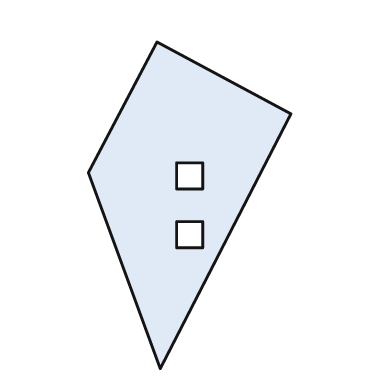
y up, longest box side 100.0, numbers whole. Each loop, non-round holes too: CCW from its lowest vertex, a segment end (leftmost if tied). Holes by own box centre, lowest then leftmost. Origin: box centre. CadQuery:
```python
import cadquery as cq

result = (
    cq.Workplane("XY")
    .moveTo(-9.0, -50.0)
    .lineTo(31.0, 28.0)
    .lineTo(-10.0, 50.0)
    .lineTo(-31.0, 10.0)
    .close()
    .moveTo(-4.0, -13.0)
    .lineTo(4.0, -13.0)
    .lineTo(4.0, -5.0)
    .lineTo(-4.0, -5.0)
    .close()
    .moveTo(-4.0, 5.0)
    .lineTo(4.0, 5.0)
    .lineTo(4.0, 13.0)
    .lineTo(-4.0, 13.0)
    .close()
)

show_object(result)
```